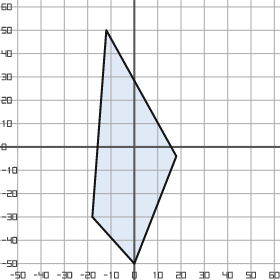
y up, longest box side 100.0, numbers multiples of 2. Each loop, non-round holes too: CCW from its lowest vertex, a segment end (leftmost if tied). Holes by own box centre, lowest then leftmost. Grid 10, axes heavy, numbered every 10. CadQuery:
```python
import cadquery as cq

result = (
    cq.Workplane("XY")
    .moveTo(0.0, -50.0)
    .lineTo(18.0, -4.0)
    .lineTo(-12.0, 50.0)
    .lineTo(-18.0, -30.0)
    .close()
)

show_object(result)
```